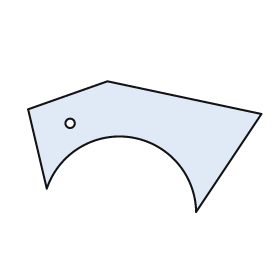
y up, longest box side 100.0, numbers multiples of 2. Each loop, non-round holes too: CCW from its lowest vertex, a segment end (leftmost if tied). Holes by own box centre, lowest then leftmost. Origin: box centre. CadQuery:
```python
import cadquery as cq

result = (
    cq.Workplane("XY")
    .moveTo(22.0, -28.0)
    .lineTo(50.0, 14.0)
    .lineTo(-16.0, 28.0)
    .lineTo(-50.0, 16.0)
    .lineTo(-42.0, -18.0)
    .threePointArc((-6.0, 4.0), (22.0, -28.0))
    .close()
    .moveTo(-32.0, 10.0)
    .circle(2.0)
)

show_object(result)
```